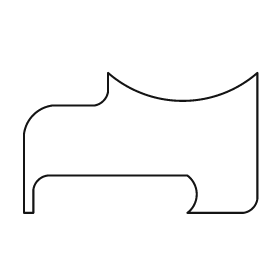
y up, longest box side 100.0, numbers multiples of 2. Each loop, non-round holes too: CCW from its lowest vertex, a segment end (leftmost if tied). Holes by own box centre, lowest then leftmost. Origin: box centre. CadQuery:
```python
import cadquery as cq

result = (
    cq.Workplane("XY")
    .moveTo(-50.0, -30.0)
    .lineTo(-46.0, -30.0)
    .lineTo(-46.0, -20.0)
    .threePointArc((-44.0, -16.0), (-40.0, -14.0))
    .lineTo(20.0, -14.0)
    .threePointArc((24.0, -22.0), (20.0, -30.0))
    .lineTo(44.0, -30.0)
    .threePointArc((48.0, -28.0), (50.0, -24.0))
    .lineTo(50.0, 30.0)
    .threePointArc((18.0, 18.0), (-14.0, 30.0))
    .lineTo(-14.0, 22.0)
    .threePointArc((-16.0, 18.0), (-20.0, 16.0))
    .lineTo(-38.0, 16.0)
    .threePointArc((-46.0, 12.0), (-50.0, 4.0))
    .close()
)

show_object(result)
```